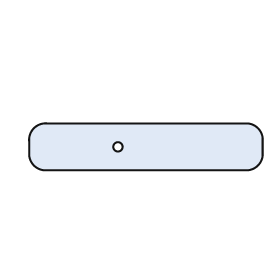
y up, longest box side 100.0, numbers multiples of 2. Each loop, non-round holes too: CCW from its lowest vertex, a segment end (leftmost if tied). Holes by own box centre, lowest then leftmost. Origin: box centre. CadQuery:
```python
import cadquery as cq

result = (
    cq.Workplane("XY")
    .moveTo(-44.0, -10.0)
    .lineTo(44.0, -10.0)
    .threePointArc((48.0, -8.0), (50.0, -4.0))
    .lineTo(50.0, 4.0)
    .threePointArc((48.0, 8.0), (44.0, 10.0))
    .lineTo(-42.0, 10.0)
    .threePointArc((-48.0, 8.0), (-50.0, 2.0))
    .lineTo(-50.0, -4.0)
    .threePointArc((-48.0, -8.0), (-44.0, -10.0))
    .close()
    .moveTo(-12.0, 0.0)
    .circle(2.0)
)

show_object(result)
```